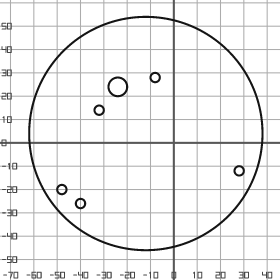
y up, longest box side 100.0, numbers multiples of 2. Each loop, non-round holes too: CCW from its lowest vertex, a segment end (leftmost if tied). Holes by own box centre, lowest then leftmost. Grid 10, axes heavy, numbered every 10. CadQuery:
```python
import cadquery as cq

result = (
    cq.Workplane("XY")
    .moveTo(-12.0, 4.0)
    .circle(50.0)
    .moveTo(-40.0, -26.0)
    .circle(2.0)
    .moveTo(-48.0, -20.0)
    .circle(2.0)
    .moveTo(28.0, -12.0)
    .circle(2.0)
    .moveTo(-32.0, 14.0)
    .circle(2.0)
    .moveTo(-24.0, 24.0)
    .circle(4.0)
    .moveTo(-8.0, 28.0)
    .circle(2.0)
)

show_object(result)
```